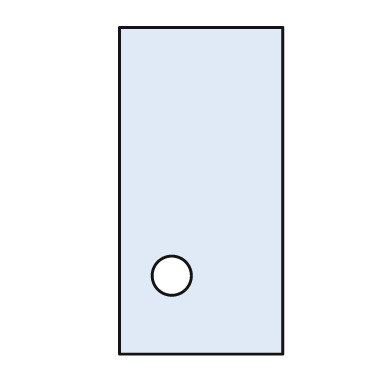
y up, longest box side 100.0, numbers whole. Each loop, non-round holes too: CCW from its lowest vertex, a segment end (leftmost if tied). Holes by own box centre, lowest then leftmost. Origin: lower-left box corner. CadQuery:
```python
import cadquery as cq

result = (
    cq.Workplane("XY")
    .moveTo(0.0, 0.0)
    .lineTo(50.0, 0.0)
    .lineTo(50.0, 100.0)
    .lineTo(0.0, 100.0)
    .close()
    .moveTo(16.0, 24.0)
    .circle(6.0)
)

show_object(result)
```